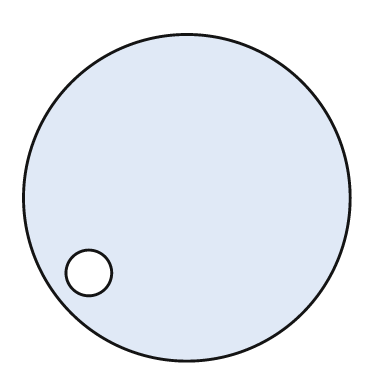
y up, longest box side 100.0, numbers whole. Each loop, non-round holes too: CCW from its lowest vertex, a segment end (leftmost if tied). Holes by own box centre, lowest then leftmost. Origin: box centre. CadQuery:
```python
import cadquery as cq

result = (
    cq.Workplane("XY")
    .moveTo(0.0, 0.0)
    .circle(50.0)
    .moveTo(-30.0, -23.0)
    .circle(7.0)
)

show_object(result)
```